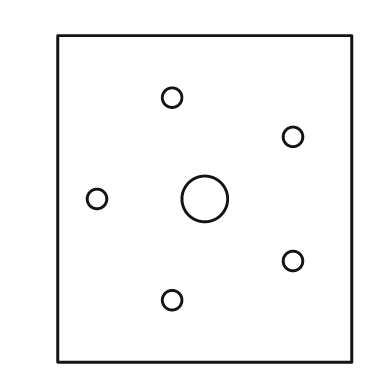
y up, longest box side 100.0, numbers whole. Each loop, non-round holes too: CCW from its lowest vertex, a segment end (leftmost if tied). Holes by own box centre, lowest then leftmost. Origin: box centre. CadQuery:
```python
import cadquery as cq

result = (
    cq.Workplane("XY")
    .moveTo(-45.0, -50.0)
    .lineTo(45.0, -50.0)
    .lineTo(45.0, 50.0)
    .lineTo(-45.0, 50.0)
    .close()
    .moveTo(-10.0, -31.0)
    .circle(3.0)
    .moveTo(27.0, -19.0)
    .circle(3.0)
    .moveTo(-33.0, 0.0)
    .circle(3.0)
    .moveTo(0.0, 0.0)
    .circle(7.0)
    .moveTo(27.0, 19.0)
    .circle(3.0)
    .moveTo(-10.0, 31.0)
    .circle(3.0)
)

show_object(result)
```